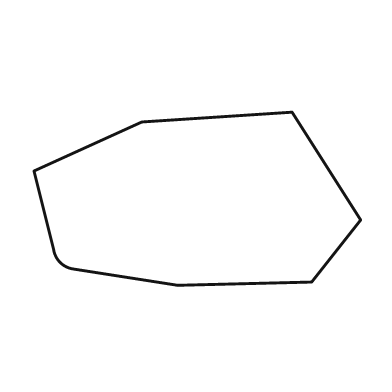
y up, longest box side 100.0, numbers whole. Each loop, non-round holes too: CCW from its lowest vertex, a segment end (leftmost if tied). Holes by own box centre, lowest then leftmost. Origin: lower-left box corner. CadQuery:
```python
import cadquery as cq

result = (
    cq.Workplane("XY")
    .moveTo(44.0, 0.0)
    .lineTo(85.0, 1.0)
    .lineTo(100.0, 20.0)
    .lineTo(79.0, 53.0)
    .lineTo(33.0, 50.0)
    .lineTo(0.0, 35.0)
    .lineTo(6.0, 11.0)
    .threePointArc((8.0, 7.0), (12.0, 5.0))
    .close()
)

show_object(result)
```